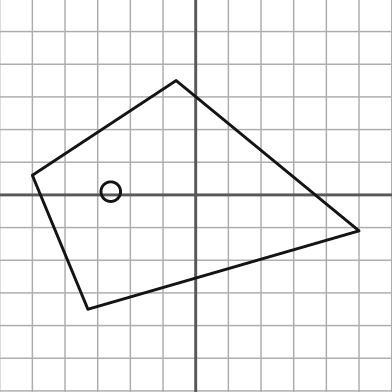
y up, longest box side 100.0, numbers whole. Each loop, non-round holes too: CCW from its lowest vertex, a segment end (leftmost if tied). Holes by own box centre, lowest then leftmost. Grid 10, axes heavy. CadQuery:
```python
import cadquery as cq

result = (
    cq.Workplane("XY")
    .moveTo(-33.0, -35.0)
    .lineTo(50.0, -11.0)
    .lineTo(-6.0, 35.0)
    .lineTo(-50.0, 6.0)
    .close()
    .moveTo(-26.0, 1.0)
    .circle(3.0)
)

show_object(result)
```